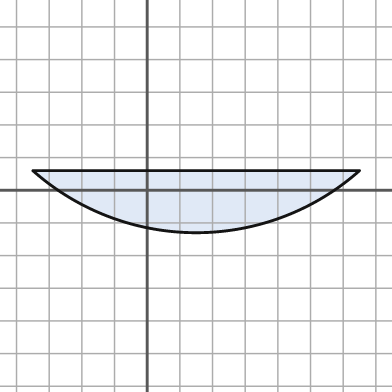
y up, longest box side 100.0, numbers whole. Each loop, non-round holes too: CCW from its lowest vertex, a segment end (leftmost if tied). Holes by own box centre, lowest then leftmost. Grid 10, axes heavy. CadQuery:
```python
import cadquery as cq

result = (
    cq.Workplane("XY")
    .moveTo(-35.0, 6.0)
    .threePointArc((15.0, -13.0), (65.0, 6.0))
    .close()
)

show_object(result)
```